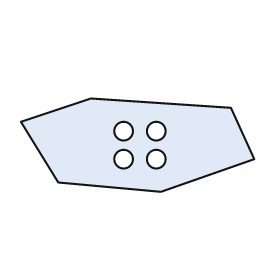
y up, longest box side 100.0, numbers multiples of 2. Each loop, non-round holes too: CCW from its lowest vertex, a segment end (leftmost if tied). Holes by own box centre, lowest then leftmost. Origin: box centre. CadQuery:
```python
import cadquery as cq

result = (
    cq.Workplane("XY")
    .moveTo(10.0, -20.0)
    .lineTo(50.0, -6.0)
    .lineTo(40.0, 16.0)
    .lineTo(-20.0, 20.0)
    .lineTo(-50.0, 10.0)
    .lineTo(-34.0, -16.0)
    .close()
    .moveTo(-6.0, -6.0)
    .circle(4.0)
    .moveTo(8.0, -6.0)
    .circle(4.0)
    .moveTo(-6.0, 6.0)
    .circle(4.0)
    .moveTo(8.0, 6.0)
    .circle(4.0)
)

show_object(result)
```